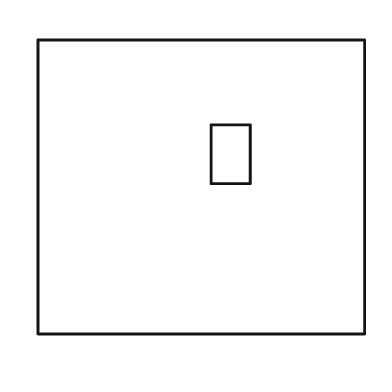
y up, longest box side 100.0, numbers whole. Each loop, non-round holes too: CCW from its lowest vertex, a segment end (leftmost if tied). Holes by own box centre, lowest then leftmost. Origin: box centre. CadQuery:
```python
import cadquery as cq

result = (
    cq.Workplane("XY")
    .moveTo(-50.0, -45.0)
    .lineTo(50.0, -45.0)
    .lineTo(50.0, 45.0)
    .lineTo(-50.0, 45.0)
    .close()
    .moveTo(3.0, 1.0)
    .lineTo(15.0, 1.0)
    .lineTo(15.0, 19.0)
    .lineTo(3.0, 19.0)
    .close()
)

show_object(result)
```